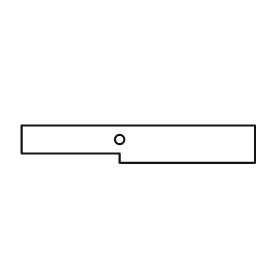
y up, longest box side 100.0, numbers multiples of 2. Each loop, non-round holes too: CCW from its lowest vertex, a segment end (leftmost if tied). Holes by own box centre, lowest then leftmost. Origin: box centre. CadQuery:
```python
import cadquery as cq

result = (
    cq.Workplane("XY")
    .moveTo(-8.0, -8.0)
    .lineTo(50.0, -8.0)
    .lineTo(50.0, 8.0)
    .lineTo(-50.0, 8.0)
    .lineTo(-50.0, -4.0)
    .lineTo(-8.0, -4.0)
    .close()
    .moveTo(-8.0, 2.0)
    .circle(2.0)
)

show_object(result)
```